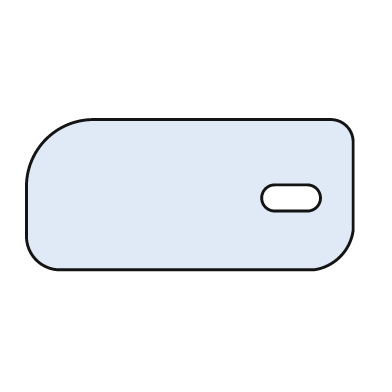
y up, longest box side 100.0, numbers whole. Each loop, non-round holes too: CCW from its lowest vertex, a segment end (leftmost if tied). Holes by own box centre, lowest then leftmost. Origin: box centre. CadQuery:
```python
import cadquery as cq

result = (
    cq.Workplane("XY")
    .moveTo(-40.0, -23.0)
    .lineTo(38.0, -23.0)
    .threePointArc((46.0, -19.0), (50.0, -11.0))
    .lineTo(50.0, 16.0)
    .threePointArc((48.0, 21.0), (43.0, 23.0))
    .lineTo(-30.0, 23.0)
    .threePointArc((-44.0, 17.0), (-50.0, 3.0))
    .lineTo(-50.0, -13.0)
    .threePointArc((-47.0, -20.0), (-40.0, -23.0))
    .close()
    .moveTo(26.0, -5.0)
    .lineTo(36.0, -5.0)
    .threePointArc((40.0, -1.0), (36.0, 3.0))
    .lineTo(26.0, 3.0)
    .threePointArc((22.0, -1.0), (26.0, -5.0))
    .close()
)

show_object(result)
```